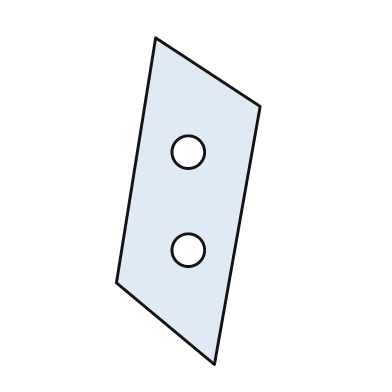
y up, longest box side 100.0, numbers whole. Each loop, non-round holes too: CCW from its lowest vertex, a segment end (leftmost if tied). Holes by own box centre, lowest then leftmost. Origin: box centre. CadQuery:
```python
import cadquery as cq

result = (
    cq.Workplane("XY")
    .moveTo(8.0, -50.0)
    .lineTo(22.0, 29.0)
    .lineTo(-10.0, 50.0)
    .lineTo(-22.0, -25.0)
    .close()
    .moveTo(0.0, -15.0)
    .circle(5.0)
    .moveTo(0.0, 15.0)
    .circle(5.0)
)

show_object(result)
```